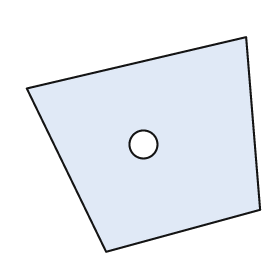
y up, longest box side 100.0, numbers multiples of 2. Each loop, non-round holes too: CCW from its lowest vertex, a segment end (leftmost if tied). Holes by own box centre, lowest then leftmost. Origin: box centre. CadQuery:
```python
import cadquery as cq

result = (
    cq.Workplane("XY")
    .moveTo(-16.0, -46.0)
    .lineTo(50.0, -28.0)
    .lineTo(44.0, 46.0)
    .lineTo(-50.0, 24.0)
    .close()
    .moveTo(0.0, 0.0)
    .circle(6.0)
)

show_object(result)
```